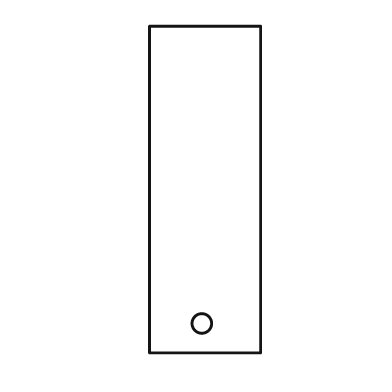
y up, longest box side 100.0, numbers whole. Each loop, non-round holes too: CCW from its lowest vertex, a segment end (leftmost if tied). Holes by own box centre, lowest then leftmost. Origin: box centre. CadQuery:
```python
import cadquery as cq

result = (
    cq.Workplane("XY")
    .moveTo(-17.0, -50.0)
    .lineTo(17.0, -50.0)
    .lineTo(17.0, 50.0)
    .lineTo(-17.0, 50.0)
    .close()
    .moveTo(-1.0, -41.0)
    .circle(3.0)
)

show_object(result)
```